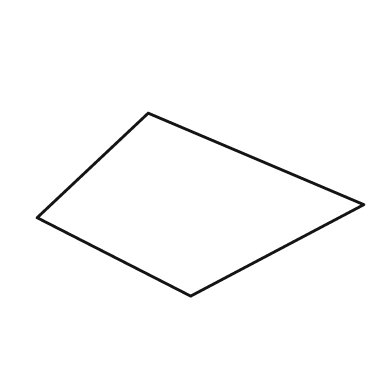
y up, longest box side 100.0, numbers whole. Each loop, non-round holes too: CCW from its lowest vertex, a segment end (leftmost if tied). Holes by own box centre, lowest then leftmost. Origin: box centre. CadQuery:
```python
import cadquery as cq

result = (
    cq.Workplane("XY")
    .moveTo(-3.0, -28.0)
    .lineTo(50.0, 0.0)
    .lineTo(-16.0, 28.0)
    .lineTo(-50.0, -4.0)
    .close()
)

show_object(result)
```